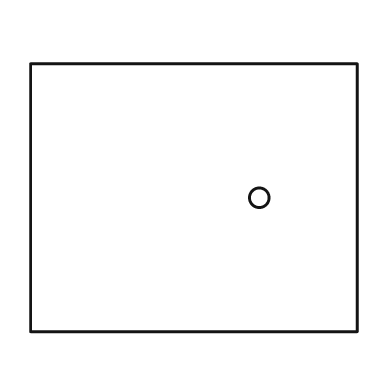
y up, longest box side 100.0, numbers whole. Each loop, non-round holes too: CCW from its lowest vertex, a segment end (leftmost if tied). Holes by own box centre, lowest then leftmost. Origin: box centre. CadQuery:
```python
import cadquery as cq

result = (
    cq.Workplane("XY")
    .moveTo(-50.0, -41.0)
    .lineTo(50.0, -41.0)
    .lineTo(50.0, 41.0)
    .lineTo(-50.0, 41.0)
    .close()
    .moveTo(20.0, 0.0)
    .circle(3.0)
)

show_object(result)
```